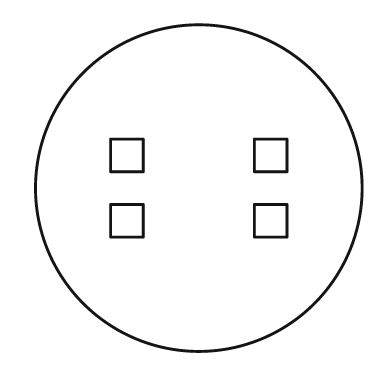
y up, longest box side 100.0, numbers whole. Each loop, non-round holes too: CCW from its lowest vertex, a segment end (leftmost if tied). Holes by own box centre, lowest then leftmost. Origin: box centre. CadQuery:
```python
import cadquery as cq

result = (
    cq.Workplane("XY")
    .moveTo(0.0, 0.0)
    .circle(50.0)
    .moveTo(-27.0, -15.0)
    .lineTo(-17.0, -15.0)
    .lineTo(-17.0, -5.0)
    .lineTo(-27.0, -5.0)
    .close()
    .moveTo(17.0, -15.0)
    .lineTo(27.0, -15.0)
    .lineTo(27.0, -5.0)
    .lineTo(17.0, -5.0)
    .close()
    .moveTo(-27.0, 5.0)
    .lineTo(-17.0, 5.0)
    .lineTo(-17.0, 15.0)
    .lineTo(-27.0, 15.0)
    .close()
    .moveTo(17.0, 5.0)
    .lineTo(27.0, 5.0)
    .lineTo(27.0, 15.0)
    .lineTo(17.0, 15.0)
    .close()
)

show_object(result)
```